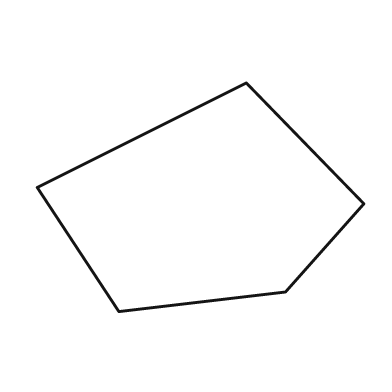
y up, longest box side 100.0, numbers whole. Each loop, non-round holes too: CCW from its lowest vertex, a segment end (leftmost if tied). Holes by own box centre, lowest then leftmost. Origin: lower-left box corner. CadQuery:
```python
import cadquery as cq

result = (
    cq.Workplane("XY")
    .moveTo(25.0, 0.0)
    .lineTo(76.0, 6.0)
    .lineTo(100.0, 33.0)
    .lineTo(64.0, 70.0)
    .lineTo(0.0, 38.0)
    .close()
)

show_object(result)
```